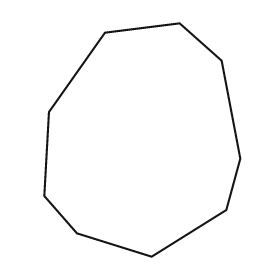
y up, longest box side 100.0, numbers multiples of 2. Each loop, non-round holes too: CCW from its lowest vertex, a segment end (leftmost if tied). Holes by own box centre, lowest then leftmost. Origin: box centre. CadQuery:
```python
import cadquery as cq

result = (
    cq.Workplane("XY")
    .moveTo(4.0, -50.0)
    .lineTo(36.0, -30.0)
    .lineTo(42.0, -8.0)
    .lineTo(34.0, 34.0)
    .lineTo(16.0, 50.0)
    .lineTo(-16.0, 46.0)
    .lineTo(-40.0, 12.0)
    .lineTo(-42.0, -24.0)
    .lineTo(-28.0, -40.0)
    .close()
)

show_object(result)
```